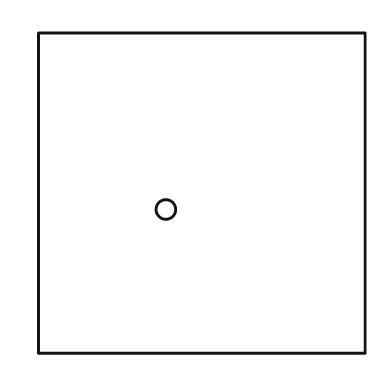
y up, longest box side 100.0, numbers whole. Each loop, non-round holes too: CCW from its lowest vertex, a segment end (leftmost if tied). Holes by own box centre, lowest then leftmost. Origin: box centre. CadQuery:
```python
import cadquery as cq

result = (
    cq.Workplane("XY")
    .moveTo(-50.0, -49.0)
    .lineTo(50.0, -49.0)
    .lineTo(50.0, 49.0)
    .lineTo(-50.0, 49.0)
    .close()
    .moveTo(-11.0, -5.0)
    .circle(3.0)
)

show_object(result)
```